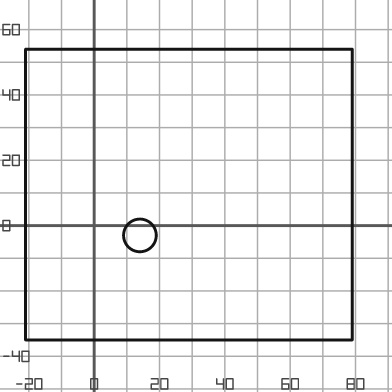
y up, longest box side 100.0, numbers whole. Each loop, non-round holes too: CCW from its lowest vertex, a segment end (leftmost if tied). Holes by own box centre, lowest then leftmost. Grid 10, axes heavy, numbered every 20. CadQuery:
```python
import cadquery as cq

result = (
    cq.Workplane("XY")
    .moveTo(-21.0, -35.0)
    .lineTo(79.0, -35.0)
    .lineTo(79.0, 54.0)
    .lineTo(-21.0, 54.0)
    .close()
    .moveTo(14.0, -3.0)
    .circle(5.0)
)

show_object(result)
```